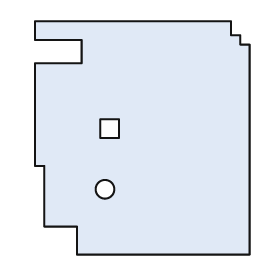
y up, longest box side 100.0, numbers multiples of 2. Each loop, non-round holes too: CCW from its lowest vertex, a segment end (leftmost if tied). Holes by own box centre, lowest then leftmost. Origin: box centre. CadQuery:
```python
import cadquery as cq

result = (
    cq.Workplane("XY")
    .moveTo(-28.0, -50.0)
    .lineTo(46.0, -50.0)
    .lineTo(46.0, 40.0)
    .lineTo(42.0, 40.0)
    .lineTo(42.0, 44.0)
    .lineTo(38.0, 44.0)
    .lineTo(38.0, 50.0)
    .lineTo(-46.0, 50.0)
    .lineTo(-46.0, 42.0)
    .lineTo(-26.0, 42.0)
    .lineTo(-26.0, 32.0)
    .lineTo(-46.0, 32.0)
    .lineTo(-46.0, -12.0)
    .lineTo(-42.0, -12.0)
    .lineTo(-42.0, -38.0)
    .lineTo(-28.0, -38.0)
    .close()
    .moveTo(-16.0, -22.0)
    .circle(4.0)
    .moveTo(-18.0, 0.0)
    .lineTo(-10.0, 0.0)
    .lineTo(-10.0, 8.0)
    .lineTo(-18.0, 8.0)
    .close()
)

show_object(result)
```